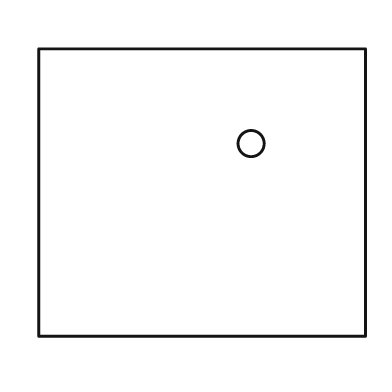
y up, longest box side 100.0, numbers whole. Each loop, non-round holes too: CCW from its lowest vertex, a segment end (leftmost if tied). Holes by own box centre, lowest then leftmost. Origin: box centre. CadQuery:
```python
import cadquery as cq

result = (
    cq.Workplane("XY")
    .moveTo(-50.0, -44.0)
    .lineTo(50.0, -44.0)
    .lineTo(50.0, 44.0)
    .lineTo(-50.0, 44.0)
    .close()
    .moveTo(15.0, 15.0)
    .circle(4.0)
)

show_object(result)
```